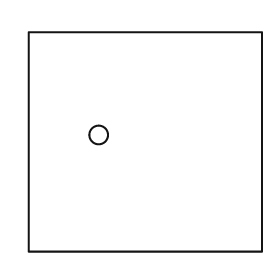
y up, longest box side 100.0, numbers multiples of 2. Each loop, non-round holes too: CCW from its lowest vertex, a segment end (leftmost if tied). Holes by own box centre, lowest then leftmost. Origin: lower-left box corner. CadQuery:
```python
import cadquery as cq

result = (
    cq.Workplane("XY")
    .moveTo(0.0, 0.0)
    .lineTo(100.0, 0.0)
    .lineTo(100.0, 94.0)
    .lineTo(0.0, 94.0)
    .close()
    .moveTo(30.0, 50.0)
    .circle(4.0)
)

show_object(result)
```